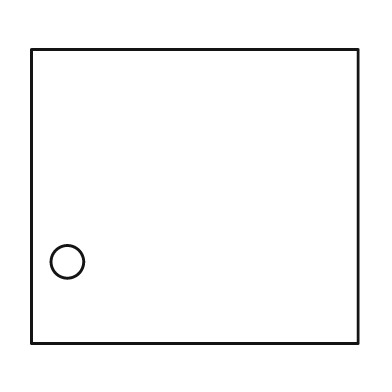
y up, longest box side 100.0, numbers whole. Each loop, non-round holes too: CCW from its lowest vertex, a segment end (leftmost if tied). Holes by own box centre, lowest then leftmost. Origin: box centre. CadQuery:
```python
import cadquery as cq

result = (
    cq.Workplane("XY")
    .moveTo(-50.0, -45.0)
    .lineTo(50.0, -45.0)
    .lineTo(50.0, 45.0)
    .lineTo(-50.0, 45.0)
    .close()
    .moveTo(-39.0, -20.0)
    .circle(5.0)
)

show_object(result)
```